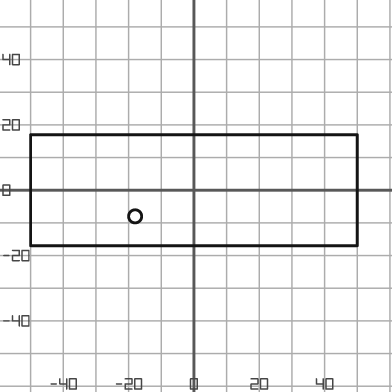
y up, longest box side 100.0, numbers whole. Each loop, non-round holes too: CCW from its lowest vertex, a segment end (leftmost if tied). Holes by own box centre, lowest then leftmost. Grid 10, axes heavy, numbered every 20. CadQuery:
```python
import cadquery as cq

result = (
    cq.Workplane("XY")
    .moveTo(-50.0, -17.0)
    .lineTo(50.0, -17.0)
    .lineTo(50.0, 17.0)
    .lineTo(-50.0, 17.0)
    .close()
    .moveTo(-18.0, -8.0)
    .circle(2.0)
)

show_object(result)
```